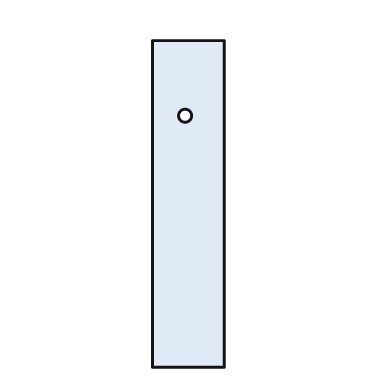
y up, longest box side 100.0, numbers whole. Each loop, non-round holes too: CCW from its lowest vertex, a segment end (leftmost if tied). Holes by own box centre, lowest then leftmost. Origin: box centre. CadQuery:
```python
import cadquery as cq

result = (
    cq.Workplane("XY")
    .moveTo(-11.0, -50.0)
    .lineTo(11.0, -50.0)
    .lineTo(11.0, 50.0)
    .lineTo(-11.0, 50.0)
    .close()
    .moveTo(-1.0, 27.0)
    .circle(2.0)
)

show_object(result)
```